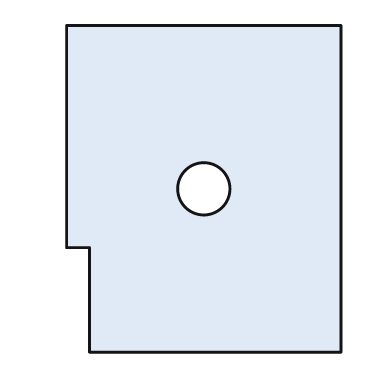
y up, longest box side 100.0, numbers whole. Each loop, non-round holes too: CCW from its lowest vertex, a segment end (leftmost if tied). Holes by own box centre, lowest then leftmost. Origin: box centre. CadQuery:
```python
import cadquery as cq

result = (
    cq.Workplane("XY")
    .moveTo(-35.0, -50.0)
    .lineTo(42.0, -50.0)
    .lineTo(42.0, 50.0)
    .lineTo(-42.0, 50.0)
    .lineTo(-42.0, -18.0)
    .lineTo(-35.0, -18.0)
    .close()
    .moveTo(0.0, 0.0)
    .circle(8.0)
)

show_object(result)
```